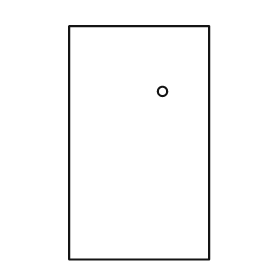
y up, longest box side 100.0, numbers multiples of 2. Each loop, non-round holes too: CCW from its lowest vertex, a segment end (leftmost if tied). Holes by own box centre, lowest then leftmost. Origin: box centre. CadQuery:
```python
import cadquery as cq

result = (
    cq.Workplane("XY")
    .moveTo(-30.0, -50.0)
    .lineTo(30.0, -50.0)
    .lineTo(30.0, 50.0)
    .lineTo(-30.0, 50.0)
    .close()
    .moveTo(10.0, 22.0)
    .circle(2.0)
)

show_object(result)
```